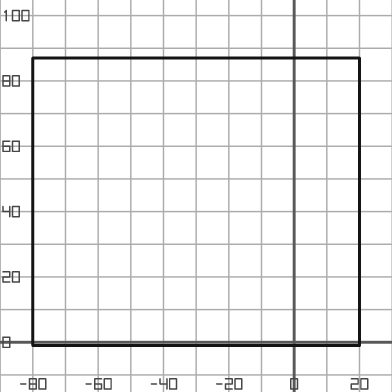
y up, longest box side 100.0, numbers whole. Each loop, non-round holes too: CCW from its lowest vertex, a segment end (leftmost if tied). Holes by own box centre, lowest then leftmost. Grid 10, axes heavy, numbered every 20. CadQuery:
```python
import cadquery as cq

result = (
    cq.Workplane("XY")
    .moveTo(-80.0, -1.0)
    .lineTo(20.0, -1.0)
    .lineTo(20.0, 87.0)
    .lineTo(-80.0, 87.0)
    .close()
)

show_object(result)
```